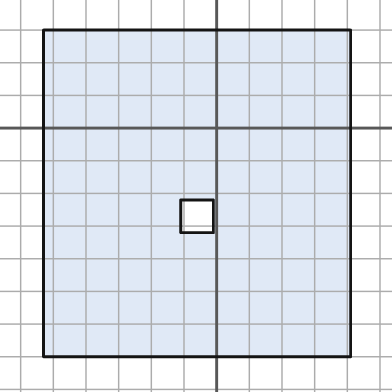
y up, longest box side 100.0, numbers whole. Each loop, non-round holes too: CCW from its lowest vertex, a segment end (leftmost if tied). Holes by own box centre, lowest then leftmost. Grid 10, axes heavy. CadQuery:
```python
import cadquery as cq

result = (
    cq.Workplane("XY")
    .moveTo(-53.0, -70.0)
    .lineTo(41.0, -70.0)
    .lineTo(41.0, 30.0)
    .lineTo(-53.0, 30.0)
    .close()
    .moveTo(-11.0, -32.0)
    .lineTo(-1.0, -32.0)
    .lineTo(-1.0, -22.0)
    .lineTo(-11.0, -22.0)
    .close()
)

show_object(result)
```